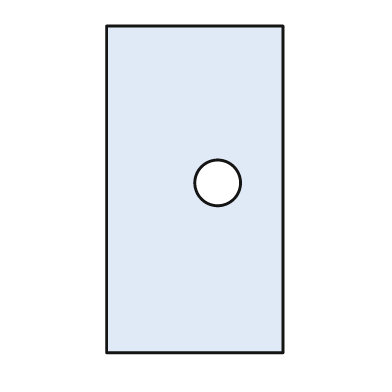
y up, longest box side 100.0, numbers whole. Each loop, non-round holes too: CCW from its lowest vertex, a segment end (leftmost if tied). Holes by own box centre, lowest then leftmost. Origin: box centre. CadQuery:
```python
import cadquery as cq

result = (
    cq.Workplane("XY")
    .moveTo(-27.0, -50.0)
    .lineTo(27.0, -50.0)
    .lineTo(27.0, 50.0)
    .lineTo(-27.0, 50.0)
    .close()
    .moveTo(7.0, 2.0)
    .circle(7.0)
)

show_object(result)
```